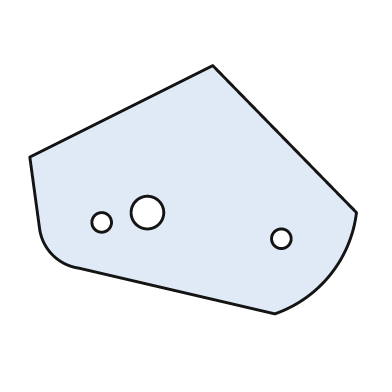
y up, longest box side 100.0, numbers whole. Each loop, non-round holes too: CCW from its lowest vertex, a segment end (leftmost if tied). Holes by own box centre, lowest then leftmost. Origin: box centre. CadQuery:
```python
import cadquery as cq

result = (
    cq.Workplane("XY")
    .moveTo(25.0, -38.0)
    .threePointArc((42.0, -26.0), (50.0, -7.0))
    .lineTo(6.0, 38.0)
    .lineTo(-50.0, 10.0)
    .lineTo(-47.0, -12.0)
    .threePointArc((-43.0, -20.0), (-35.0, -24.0))
    .close()
    .moveTo(27.0, -15.0)
    .circle(3.0)
    .moveTo(-28.0, -10.0)
    .circle(3.0)
    .moveTo(-14.0, -7.0)
    .circle(5.0)
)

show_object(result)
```